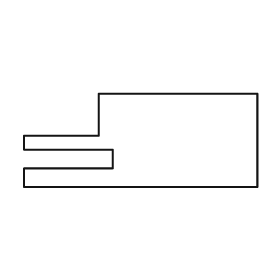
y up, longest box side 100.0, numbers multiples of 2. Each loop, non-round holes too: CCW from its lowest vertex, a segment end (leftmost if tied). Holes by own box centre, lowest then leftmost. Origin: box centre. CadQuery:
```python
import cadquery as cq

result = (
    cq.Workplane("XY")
    .moveTo(-50.0, -20.0)
    .lineTo(50.0, -20.0)
    .lineTo(50.0, 20.0)
    .lineTo(-18.0, 20.0)
    .lineTo(-18.0, 2.0)
    .lineTo(-50.0, 2.0)
    .lineTo(-50.0, -4.0)
    .lineTo(-12.0, -4.0)
    .lineTo(-12.0, -12.0)
    .lineTo(-50.0, -12.0)
    .close()
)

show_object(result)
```